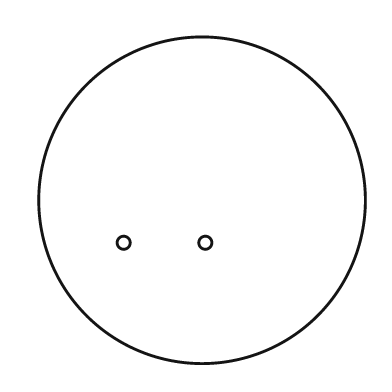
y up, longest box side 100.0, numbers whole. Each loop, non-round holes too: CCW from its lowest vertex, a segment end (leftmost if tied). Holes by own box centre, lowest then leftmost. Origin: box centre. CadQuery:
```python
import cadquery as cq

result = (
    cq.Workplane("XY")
    .moveTo(0.0, 0.0)
    .circle(50.0)
    .moveTo(-24.0, -13.0)
    .circle(2.0)
    .moveTo(1.0, -13.0)
    .circle(2.0)
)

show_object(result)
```